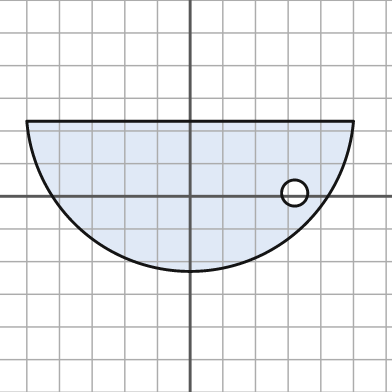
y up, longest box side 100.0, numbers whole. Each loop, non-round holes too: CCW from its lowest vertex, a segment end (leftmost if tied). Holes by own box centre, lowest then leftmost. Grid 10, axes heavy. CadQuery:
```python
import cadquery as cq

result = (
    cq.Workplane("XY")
    .moveTo(-50.0, 23.0)
    .threePointArc((0.0, -23.0), (50.0, 23.0))
    .close()
    .moveTo(32.0, 1.0)
    .circle(4.0)
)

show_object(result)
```